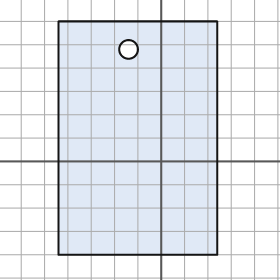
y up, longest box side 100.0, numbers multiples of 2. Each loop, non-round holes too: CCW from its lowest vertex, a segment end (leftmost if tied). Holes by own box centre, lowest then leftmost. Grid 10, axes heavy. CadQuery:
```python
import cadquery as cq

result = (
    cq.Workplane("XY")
    .moveTo(-44.0, -40.0)
    .lineTo(24.0, -40.0)
    .lineTo(24.0, 60.0)
    .lineTo(-44.0, 60.0)
    .close()
    .moveTo(-14.0, 48.0)
    .circle(4.0)
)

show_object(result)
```